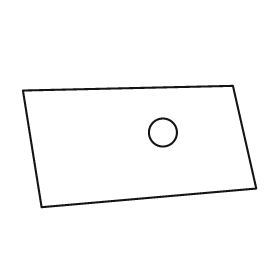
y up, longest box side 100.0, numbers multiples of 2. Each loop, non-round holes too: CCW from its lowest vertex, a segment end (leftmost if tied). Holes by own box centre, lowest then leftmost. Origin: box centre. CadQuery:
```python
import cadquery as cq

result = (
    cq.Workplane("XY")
    .moveTo(-42.0, -26.0)
    .lineTo(50.0, -18.0)
    .lineTo(40.0, 26.0)
    .lineTo(-50.0, 24.0)
    .close()
    .moveTo(10.0, 6.0)
    .circle(6.0)
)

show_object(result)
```